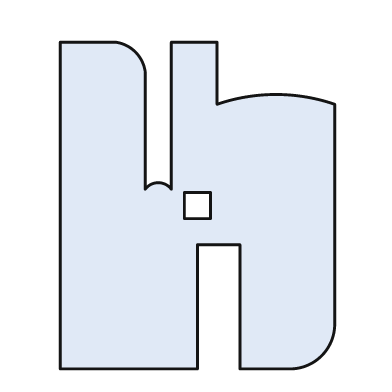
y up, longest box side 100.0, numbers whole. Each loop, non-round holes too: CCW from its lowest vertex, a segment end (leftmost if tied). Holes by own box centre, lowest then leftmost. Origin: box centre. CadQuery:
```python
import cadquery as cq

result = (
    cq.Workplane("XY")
    .moveTo(-42.0, -50.0)
    .lineTo(0.0, -50.0)
    .lineTo(0.0, -12.0)
    .lineTo(13.0, -12.0)
    .lineTo(13.0, -50.0)
    .lineTo(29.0, -50.0)
    .threePointArc((38.0, -46.0), (42.0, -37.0))
    .lineTo(42.0, 31.0)
    .threePointArc((24.0, 34.0), (6.0, 31.0))
    .lineTo(6.0, 50.0)
    .lineTo(-8.0, 50.0)
    .lineTo(-8.0, 5.0)
    .threePointArc((-12.0, 7.0), (-16.0, 5.0))
    .lineTo(-16.0, 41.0)
    .threePointArc((-19.0, 47.0), (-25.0, 50.0))
    .lineTo(-42.0, 50.0)
    .close()
    .moveTo(-4.0, -4.0)
    .lineTo(4.0, -4.0)
    .lineTo(4.0, 4.0)
    .lineTo(-4.0, 4.0)
    .close()
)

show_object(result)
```